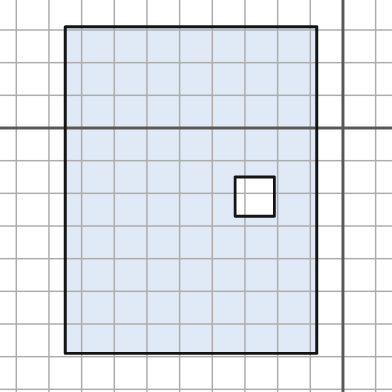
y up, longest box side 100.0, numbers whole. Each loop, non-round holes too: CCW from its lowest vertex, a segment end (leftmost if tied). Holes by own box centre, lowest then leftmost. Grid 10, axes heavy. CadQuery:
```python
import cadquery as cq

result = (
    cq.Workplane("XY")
    .moveTo(-85.0, -69.0)
    .lineTo(-8.0, -69.0)
    .lineTo(-8.0, 31.0)
    .lineTo(-85.0, 31.0)
    .close()
    .moveTo(-33.0, -27.0)
    .lineTo(-21.0, -27.0)
    .lineTo(-21.0, -15.0)
    .lineTo(-33.0, -15.0)
    .close()
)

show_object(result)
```